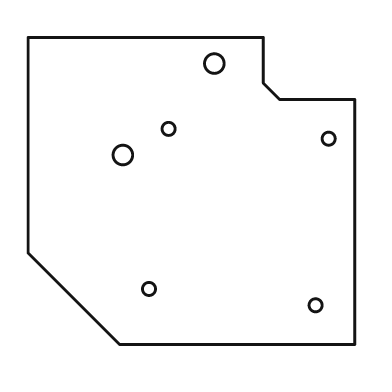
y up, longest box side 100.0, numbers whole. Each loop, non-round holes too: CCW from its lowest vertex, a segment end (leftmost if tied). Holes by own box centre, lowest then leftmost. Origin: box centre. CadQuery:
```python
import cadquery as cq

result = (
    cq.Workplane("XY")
    .moveTo(-22.0, -47.0)
    .lineTo(50.0, -47.0)
    .lineTo(50.0, 28.0)
    .lineTo(27.0, 28.0)
    .lineTo(22.0, 33.0)
    .lineTo(22.0, 47.0)
    .lineTo(-50.0, 47.0)
    .lineTo(-50.0, -19.0)
    .close()
    .moveTo(38.0, -35.0)
    .circle(2.0)
    .moveTo(-13.0, -30.0)
    .circle(2.0)
    .moveTo(-21.0, 11.0)
    .circle(3.0)
    .moveTo(42.0, 16.0)
    .circle(2.0)
    .moveTo(-7.0, 19.0)
    .circle(2.0)
    .moveTo(7.0, 39.0)
    .circle(3.0)
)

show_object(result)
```